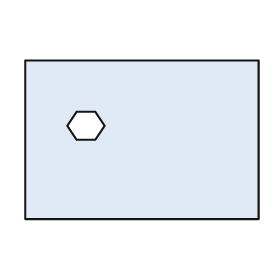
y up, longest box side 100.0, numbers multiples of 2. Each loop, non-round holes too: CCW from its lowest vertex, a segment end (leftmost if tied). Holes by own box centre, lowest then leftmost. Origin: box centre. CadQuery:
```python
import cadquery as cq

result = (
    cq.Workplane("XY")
    .moveTo(-50.0, -34.0)
    .lineTo(50.0, -34.0)
    .lineTo(50.0, 34.0)
    .lineTo(-50.0, 34.0)
    .close()
    .moveTo(-28.0, 0.0)
    .lineTo(-20.0, 0.0)
    .lineTo(-16.0, 6.0)
    .lineTo(-20.0, 12.0)
    .lineTo(-28.0, 12.0)
    .lineTo(-32.0, 6.0)
    .close()
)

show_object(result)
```